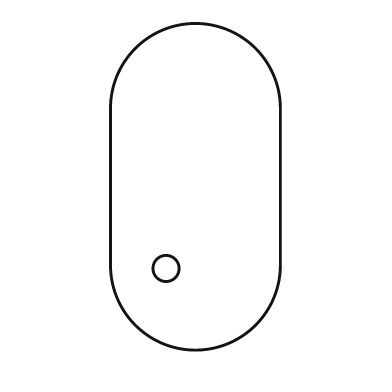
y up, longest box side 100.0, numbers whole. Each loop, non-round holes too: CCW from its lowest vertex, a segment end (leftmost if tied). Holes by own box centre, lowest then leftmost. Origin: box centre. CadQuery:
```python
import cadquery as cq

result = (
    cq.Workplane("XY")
    .moveTo(-26.0, -24.0)
    .threePointArc((0.0, -50.0), (26.0, -24.0))
    .lineTo(26.0, 24.0)
    .threePointArc((0.0, 50.0), (-26.0, 24.0))
    .close()
    .moveTo(-9.0, -25.0)
    .circle(4.0)
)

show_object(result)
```